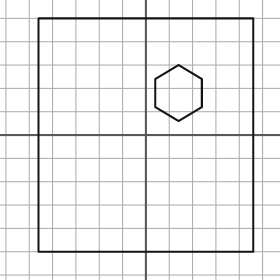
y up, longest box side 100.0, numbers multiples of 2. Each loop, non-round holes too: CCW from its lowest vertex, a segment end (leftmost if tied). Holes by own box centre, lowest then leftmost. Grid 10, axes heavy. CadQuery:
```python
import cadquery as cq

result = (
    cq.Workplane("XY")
    .moveTo(-46.0, -50.0)
    .lineTo(46.0, -50.0)
    .lineTo(46.0, 50.0)
    .lineTo(-46.0, 50.0)
    .close()
    .moveTo(14.0, 6.0)
    .lineTo(24.0, 12.0)
    .lineTo(24.0, 24.0)
    .lineTo(14.0, 30.0)
    .lineTo(4.0, 24.0)
    .lineTo(4.0, 12.0)
    .close()
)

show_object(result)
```